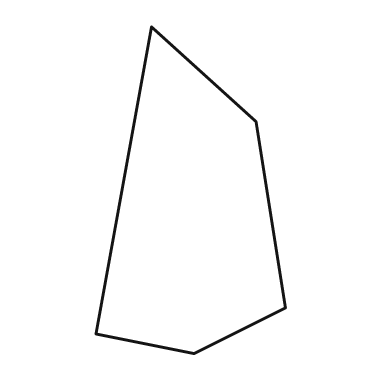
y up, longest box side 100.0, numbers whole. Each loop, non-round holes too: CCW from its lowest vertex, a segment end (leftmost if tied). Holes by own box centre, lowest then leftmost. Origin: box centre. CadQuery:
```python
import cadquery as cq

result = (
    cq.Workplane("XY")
    .moveTo(1.0, -50.0)
    .lineTo(29.0, -36.0)
    .lineTo(20.0, 21.0)
    .lineTo(-12.0, 50.0)
    .lineTo(-29.0, -44.0)
    .close()
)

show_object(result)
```